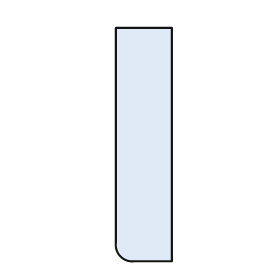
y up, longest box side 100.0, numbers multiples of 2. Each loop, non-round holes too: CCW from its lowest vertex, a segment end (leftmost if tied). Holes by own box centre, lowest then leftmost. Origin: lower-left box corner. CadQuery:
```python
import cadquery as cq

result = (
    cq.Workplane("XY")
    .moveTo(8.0, 0.0)
    .lineTo(24.0, 0.0)
    .lineTo(24.0, 100.0)
    .lineTo(0.0, 100.0)
    .lineTo(0.0, 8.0)
    .threePointArc((2.0, 2.0), (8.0, 0.0))
    .close()
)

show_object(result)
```